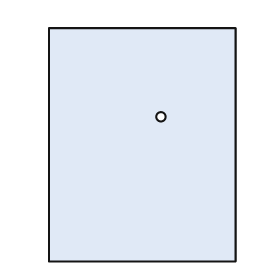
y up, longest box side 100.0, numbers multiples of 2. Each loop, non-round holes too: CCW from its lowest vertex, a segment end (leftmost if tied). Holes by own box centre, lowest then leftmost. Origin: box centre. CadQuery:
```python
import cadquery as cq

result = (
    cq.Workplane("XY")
    .moveTo(-40.0, -50.0)
    .lineTo(40.0, -50.0)
    .lineTo(40.0, 50.0)
    .lineTo(-40.0, 50.0)
    .close()
    .moveTo(8.0, 12.0)
    .circle(2.0)
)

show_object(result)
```